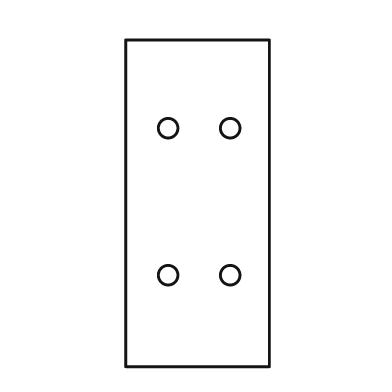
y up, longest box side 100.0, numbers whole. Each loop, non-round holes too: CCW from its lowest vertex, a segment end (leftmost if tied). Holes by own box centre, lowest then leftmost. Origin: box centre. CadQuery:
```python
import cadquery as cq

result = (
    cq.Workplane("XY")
    .moveTo(-22.0, -50.0)
    .lineTo(22.0, -50.0)
    .lineTo(22.0, 50.0)
    .lineTo(-22.0, 50.0)
    .close()
    .moveTo(-9.0, -22.0)
    .circle(3.0)
    .moveTo(10.0, -22.0)
    .circle(3.0)
    .moveTo(-9.0, 23.0)
    .circle(3.0)
    .moveTo(10.0, 23.0)
    .circle(3.0)
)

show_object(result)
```